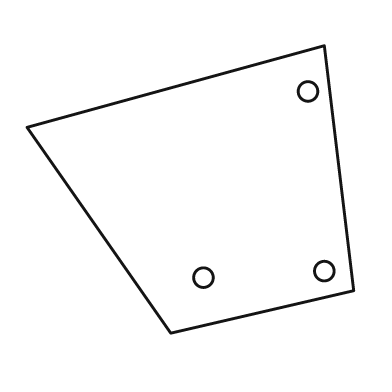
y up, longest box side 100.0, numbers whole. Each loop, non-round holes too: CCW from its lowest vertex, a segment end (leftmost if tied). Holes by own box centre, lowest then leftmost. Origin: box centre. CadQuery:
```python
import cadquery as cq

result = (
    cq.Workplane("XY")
    .moveTo(-6.0, -44.0)
    .lineTo(50.0, -31.0)
    .lineTo(41.0, 44.0)
    .lineTo(-50.0, 19.0)
    .close()
    .moveTo(4.0, -27.0)
    .circle(3.0)
    .moveTo(41.0, -25.0)
    .circle(3.0)
    .moveTo(36.0, 30.0)
    .circle(3.0)
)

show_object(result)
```